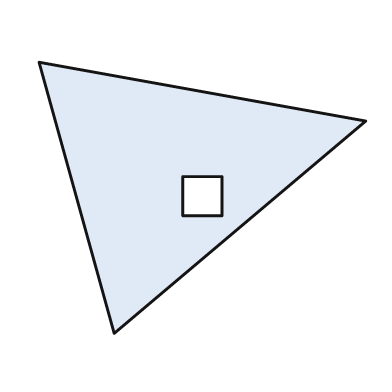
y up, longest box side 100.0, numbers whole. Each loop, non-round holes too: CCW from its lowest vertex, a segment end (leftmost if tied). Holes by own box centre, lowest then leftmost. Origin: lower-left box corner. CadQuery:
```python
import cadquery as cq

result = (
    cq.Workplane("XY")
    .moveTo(23.0, 0.0)
    .lineTo(100.0, 65.0)
    .lineTo(0.0, 83.0)
    .close()
    .moveTo(44.0, 36.0)
    .lineTo(56.0, 36.0)
    .lineTo(56.0, 48.0)
    .lineTo(44.0, 48.0)
    .close()
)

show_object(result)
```